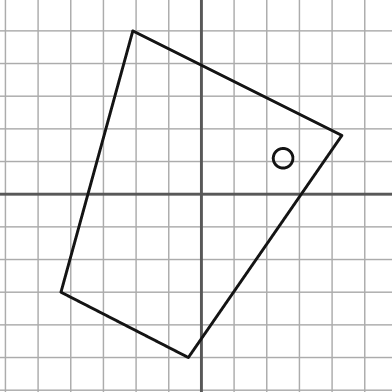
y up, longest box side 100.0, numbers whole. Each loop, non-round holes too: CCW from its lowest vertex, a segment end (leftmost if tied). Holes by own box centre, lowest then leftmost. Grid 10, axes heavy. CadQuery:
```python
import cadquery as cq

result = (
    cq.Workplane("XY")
    .moveTo(-4.0, -50.0)
    .lineTo(43.0, 18.0)
    .lineTo(-21.0, 50.0)
    .lineTo(-43.0, -30.0)
    .close()
    .moveTo(25.0, 11.0)
    .circle(3.0)
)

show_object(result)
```